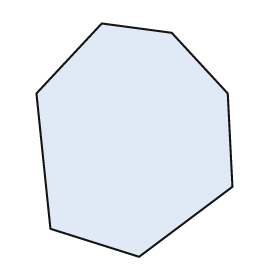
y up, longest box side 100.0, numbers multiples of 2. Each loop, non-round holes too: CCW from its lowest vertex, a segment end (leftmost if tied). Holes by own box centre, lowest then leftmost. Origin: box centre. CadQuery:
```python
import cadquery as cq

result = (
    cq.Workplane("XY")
    .moveTo(2.0, -50.0)
    .lineTo(42.0, -20.0)
    .lineTo(40.0, 20.0)
    .lineTo(16.0, 46.0)
    .lineTo(-14.0, 50.0)
    .lineTo(-42.0, 20.0)
    .lineTo(-36.0, -38.0)
    .close()
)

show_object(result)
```